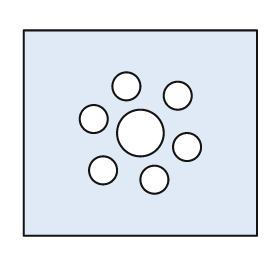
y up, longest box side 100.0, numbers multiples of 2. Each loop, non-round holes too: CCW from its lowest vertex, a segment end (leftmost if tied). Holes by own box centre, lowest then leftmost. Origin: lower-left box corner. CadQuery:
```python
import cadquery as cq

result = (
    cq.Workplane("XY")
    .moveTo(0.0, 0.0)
    .lineTo(100.0, 0.0)
    .lineTo(100.0, 88.0)
    .lineTo(0.0, 88.0)
    .close()
    .moveTo(56.0, 24.0)
    .circle(6.0)
    .moveTo(34.0, 28.0)
    .circle(6.0)
    .moveTo(70.0, 38.0)
    .circle(6.0)
    .moveTo(50.0, 44.0)
    .circle(10.0)
    .moveTo(30.0, 50.0)
    .circle(6.0)
    .moveTo(66.0, 60.0)
    .circle(6.0)
    .moveTo(44.0, 64.0)
    .circle(6.0)
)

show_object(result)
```